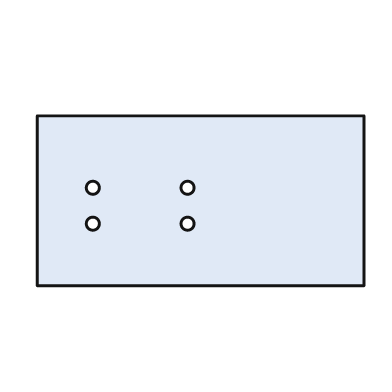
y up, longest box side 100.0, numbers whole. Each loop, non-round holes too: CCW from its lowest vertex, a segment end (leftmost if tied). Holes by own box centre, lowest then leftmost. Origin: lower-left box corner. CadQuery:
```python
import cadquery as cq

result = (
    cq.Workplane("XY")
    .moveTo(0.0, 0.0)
    .lineTo(100.0, 0.0)
    .lineTo(100.0, 52.0)
    .lineTo(0.0, 52.0)
    .close()
    .moveTo(17.0, 19.0)
    .circle(2.0)
    .moveTo(46.0, 19.0)
    .circle(2.0)
    .moveTo(17.0, 30.0)
    .circle(2.0)
    .moveTo(46.0, 30.0)
    .circle(2.0)
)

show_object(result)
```